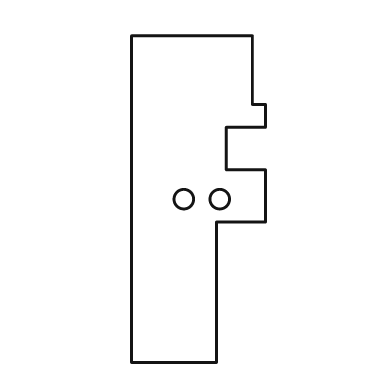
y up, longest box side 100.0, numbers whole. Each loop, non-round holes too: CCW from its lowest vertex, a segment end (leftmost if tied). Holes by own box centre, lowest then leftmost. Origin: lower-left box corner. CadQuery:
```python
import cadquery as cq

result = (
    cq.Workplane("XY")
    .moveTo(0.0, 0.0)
    .lineTo(26.0, 0.0)
    .lineTo(26.0, 43.0)
    .lineTo(41.0, 43.0)
    .lineTo(41.0, 59.0)
    .lineTo(29.0, 59.0)
    .lineTo(29.0, 72.0)
    .lineTo(41.0, 72.0)
    .lineTo(41.0, 79.0)
    .lineTo(37.0, 79.0)
    .lineTo(37.0, 100.0)
    .lineTo(0.0, 100.0)
    .close()
    .moveTo(16.0, 50.0)
    .circle(3.0)
    .moveTo(27.0, 50.0)
    .circle(3.0)
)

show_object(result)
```